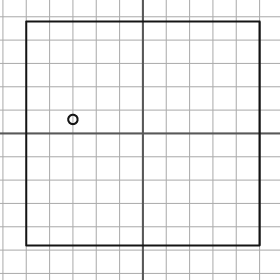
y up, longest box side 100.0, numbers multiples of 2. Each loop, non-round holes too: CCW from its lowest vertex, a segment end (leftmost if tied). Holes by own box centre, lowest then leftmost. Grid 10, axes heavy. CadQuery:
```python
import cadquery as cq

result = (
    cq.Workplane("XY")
    .moveTo(-50.0, -48.0)
    .lineTo(50.0, -48.0)
    .lineTo(50.0, 48.0)
    .lineTo(-50.0, 48.0)
    .close()
    .moveTo(-30.0, 6.0)
    .circle(2.0)
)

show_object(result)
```